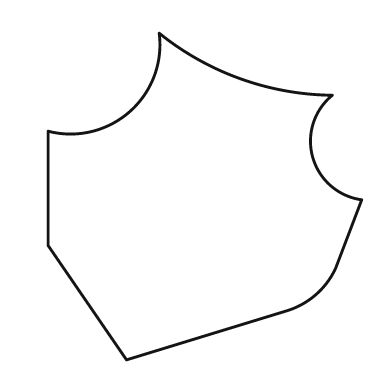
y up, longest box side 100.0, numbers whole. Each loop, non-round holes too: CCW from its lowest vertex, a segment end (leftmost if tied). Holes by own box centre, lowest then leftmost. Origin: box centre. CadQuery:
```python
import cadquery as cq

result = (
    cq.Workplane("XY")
    .moveTo(-24.0, -50.0)
    .lineTo(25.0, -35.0)
    .threePointArc((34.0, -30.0), (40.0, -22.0))
    .lineTo(48.0, -1.0)
    .threePointArc((33.0, 12.0), (39.0, 31.0))
    .threePointArc((11.0, 36.0), (-14.0, 50.0))
    .threePointArc((-23.0, 26.0), (-48.0, 20.0))
    .lineTo(-48.0, -15.0)
    .close()
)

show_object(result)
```